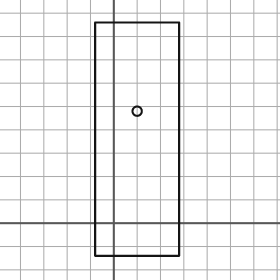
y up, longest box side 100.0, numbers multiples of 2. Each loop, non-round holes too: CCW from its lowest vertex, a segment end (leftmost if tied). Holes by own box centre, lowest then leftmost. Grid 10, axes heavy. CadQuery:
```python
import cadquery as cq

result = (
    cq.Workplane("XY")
    .moveTo(-8.0, -14.0)
    .lineTo(28.0, -14.0)
    .lineTo(28.0, 86.0)
    .lineTo(-8.0, 86.0)
    .close()
    .moveTo(10.0, 48.0)
    .circle(2.0)
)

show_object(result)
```